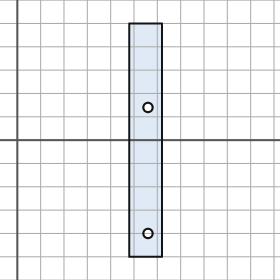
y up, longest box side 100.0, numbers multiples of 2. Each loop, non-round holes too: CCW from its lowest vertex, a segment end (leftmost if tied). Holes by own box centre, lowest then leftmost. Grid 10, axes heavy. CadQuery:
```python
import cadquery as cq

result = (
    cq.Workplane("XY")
    .moveTo(48.0, -50.0)
    .lineTo(62.0, -50.0)
    .lineTo(62.0, 50.0)
    .lineTo(48.0, 50.0)
    .close()
    .moveTo(56.0, -40.0)
    .circle(2.0)
    .moveTo(56.0, 14.0)
    .circle(2.0)
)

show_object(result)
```